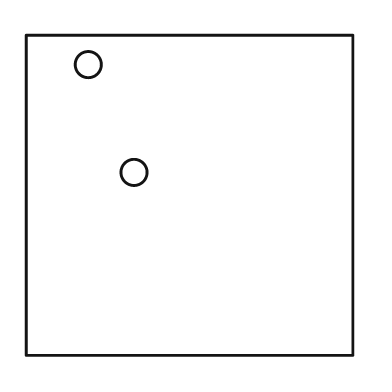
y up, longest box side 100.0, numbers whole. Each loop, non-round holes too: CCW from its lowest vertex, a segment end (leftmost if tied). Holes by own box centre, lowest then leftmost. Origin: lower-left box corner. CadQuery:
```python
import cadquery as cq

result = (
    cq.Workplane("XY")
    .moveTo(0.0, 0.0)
    .lineTo(100.0, 0.0)
    .lineTo(100.0, 98.0)
    .lineTo(0.0, 98.0)
    .close()
    .moveTo(33.0, 56.0)
    .circle(4.0)
    .moveTo(19.0, 89.0)
    .circle(4.0)
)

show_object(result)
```